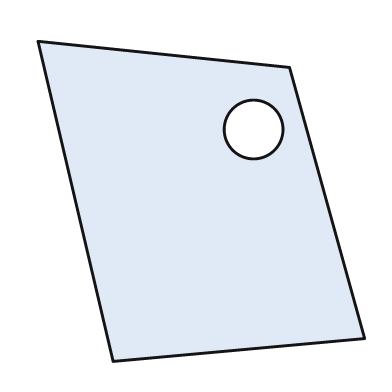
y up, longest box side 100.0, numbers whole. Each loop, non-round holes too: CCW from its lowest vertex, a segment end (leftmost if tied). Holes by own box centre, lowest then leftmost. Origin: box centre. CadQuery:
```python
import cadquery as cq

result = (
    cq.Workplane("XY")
    .moveTo(-27.0, -49.0)
    .lineTo(50.0, -42.0)
    .lineTo(27.0, 41.0)
    .lineTo(-50.0, 49.0)
    .close()
    .moveTo(16.0, 22.0)
    .circle(9.0)
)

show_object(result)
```